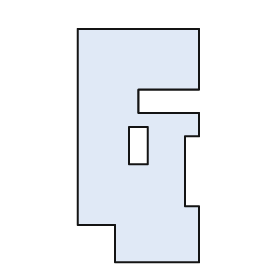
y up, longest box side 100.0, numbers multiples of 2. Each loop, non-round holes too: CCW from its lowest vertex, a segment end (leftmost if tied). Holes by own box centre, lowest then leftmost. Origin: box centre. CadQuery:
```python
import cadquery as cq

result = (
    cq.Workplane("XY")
    .moveTo(-10.0, -50.0)
    .lineTo(26.0, -50.0)
    .lineTo(26.0, -26.0)
    .lineTo(20.0, -26.0)
    .lineTo(20.0, 4.0)
    .lineTo(26.0, 4.0)
    .lineTo(26.0, 14.0)
    .lineTo(0.0, 14.0)
    .lineTo(0.0, 24.0)
    .lineTo(26.0, 24.0)
    .lineTo(26.0, 50.0)
    .lineTo(-26.0, 50.0)
    .lineTo(-26.0, -34.0)
    .lineTo(-10.0, -34.0)
    .close()
    .moveTo(-4.0, -8.0)
    .lineTo(4.0, -8.0)
    .lineTo(4.0, 8.0)
    .lineTo(-4.0, 8.0)
    .close()
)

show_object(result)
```